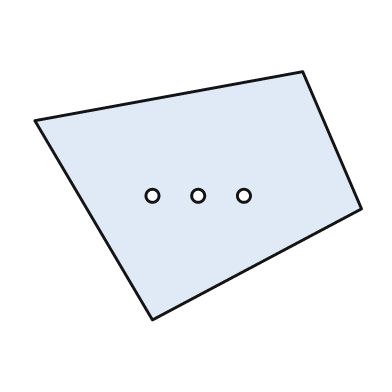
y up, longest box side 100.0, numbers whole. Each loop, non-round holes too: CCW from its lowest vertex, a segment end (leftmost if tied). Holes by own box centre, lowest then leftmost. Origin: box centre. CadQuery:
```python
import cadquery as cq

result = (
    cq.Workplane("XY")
    .moveTo(-14.0, -38.0)
    .lineTo(50.0, -4.0)
    .lineTo(32.0, 38.0)
    .lineTo(-50.0, 23.0)
    .close()
    .moveTo(-14.0, 0.0)
    .circle(2.0)
    .moveTo(0.0, 0.0)
    .circle(2.0)
    .moveTo(14.0, 0.0)
    .circle(2.0)
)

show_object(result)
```